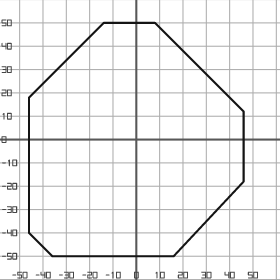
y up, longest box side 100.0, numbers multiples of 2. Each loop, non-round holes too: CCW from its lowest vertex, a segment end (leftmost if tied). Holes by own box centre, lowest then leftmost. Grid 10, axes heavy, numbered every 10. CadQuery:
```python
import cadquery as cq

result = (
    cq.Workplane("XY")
    .moveTo(-36.0, -50.0)
    .lineTo(16.0, -50.0)
    .lineTo(46.0, -18.0)
    .lineTo(46.0, 12.0)
    .lineTo(8.0, 50.0)
    .lineTo(-14.0, 50.0)
    .lineTo(-46.0, 18.0)
    .lineTo(-46.0, -40.0)
    .close()
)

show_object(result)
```